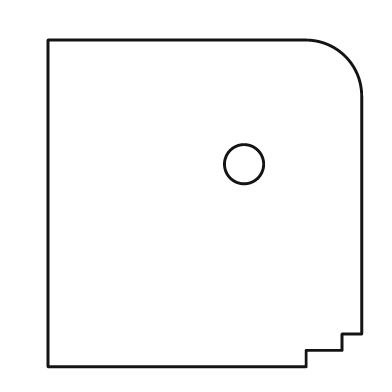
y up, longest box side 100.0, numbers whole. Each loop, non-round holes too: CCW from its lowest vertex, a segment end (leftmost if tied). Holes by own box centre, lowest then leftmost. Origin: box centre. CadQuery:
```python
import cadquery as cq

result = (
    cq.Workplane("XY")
    .moveTo(-48.0, -50.0)
    .lineTo(31.0, -50.0)
    .lineTo(31.0, -45.0)
    .lineTo(42.0, -45.0)
    .lineTo(42.0, -40.0)
    .lineTo(48.0, -40.0)
    .lineTo(48.0, 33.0)
    .threePointArc((43.0, 45.0), (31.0, 50.0))
    .lineTo(-48.0, 50.0)
    .close()
    .moveTo(12.0, 12.0)
    .circle(6.0)
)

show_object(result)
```